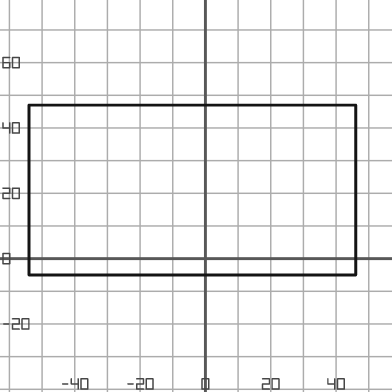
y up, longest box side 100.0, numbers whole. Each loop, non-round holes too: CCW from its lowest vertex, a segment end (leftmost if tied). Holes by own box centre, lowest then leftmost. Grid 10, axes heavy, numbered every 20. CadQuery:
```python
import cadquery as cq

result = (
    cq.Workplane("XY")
    .moveTo(-54.0, -5.0)
    .lineTo(46.0, -5.0)
    .lineTo(46.0, 47.0)
    .lineTo(-54.0, 47.0)
    .close()
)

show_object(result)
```